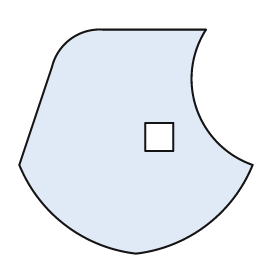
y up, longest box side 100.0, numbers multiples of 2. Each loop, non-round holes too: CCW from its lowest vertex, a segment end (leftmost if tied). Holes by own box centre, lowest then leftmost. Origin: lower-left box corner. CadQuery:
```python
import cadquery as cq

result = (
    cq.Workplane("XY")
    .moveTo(50.0, 0.0)
    .threePointArc((80.0, 12.0), (100.0, 38.0))
    .threePointArc((76.0, 62.0), (80.0, 96.0))
    .lineTo(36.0, 96.0)
    .threePointArc((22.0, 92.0), (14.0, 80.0))
    .lineTo(0.0, 38.0)
    .threePointArc((20.0, 12.0), (50.0, 0.0))
    .close()
    .moveTo(54.0, 44.0)
    .lineTo(66.0, 44.0)
    .lineTo(66.0, 56.0)
    .lineTo(54.0, 56.0)
    .close()
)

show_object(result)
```